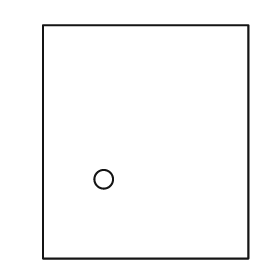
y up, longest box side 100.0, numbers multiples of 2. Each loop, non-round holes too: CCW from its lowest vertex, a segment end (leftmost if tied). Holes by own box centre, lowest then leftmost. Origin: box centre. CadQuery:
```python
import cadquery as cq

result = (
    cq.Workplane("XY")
    .moveTo(-44.0, -50.0)
    .lineTo(44.0, -50.0)
    .lineTo(44.0, 50.0)
    .lineTo(-44.0, 50.0)
    .close()
    .moveTo(-18.0, -16.0)
    .circle(4.0)
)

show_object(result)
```